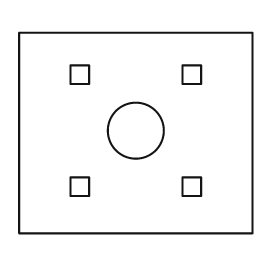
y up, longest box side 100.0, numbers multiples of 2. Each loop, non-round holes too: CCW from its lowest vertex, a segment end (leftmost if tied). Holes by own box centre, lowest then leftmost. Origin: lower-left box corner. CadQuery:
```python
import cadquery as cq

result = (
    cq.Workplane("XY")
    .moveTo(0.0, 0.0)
    .lineTo(100.0, 0.0)
    .lineTo(100.0, 86.0)
    .lineTo(0.0, 86.0)
    .close()
    .moveTo(22.0, 16.0)
    .lineTo(30.0, 16.0)
    .lineTo(30.0, 24.0)
    .lineTo(22.0, 24.0)
    .close()
    .moveTo(70.0, 16.0)
    .lineTo(78.0, 16.0)
    .lineTo(78.0, 24.0)
    .lineTo(70.0, 24.0)
    .close()
    .moveTo(50.0, 44.0)
    .circle(12.0)
    .moveTo(22.0, 64.0)
    .lineTo(30.0, 64.0)
    .lineTo(30.0, 72.0)
    .lineTo(22.0, 72.0)
    .close()
    .moveTo(70.0, 64.0)
    .lineTo(78.0, 64.0)
    .lineTo(78.0, 72.0)
    .lineTo(70.0, 72.0)
    .close()
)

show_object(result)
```